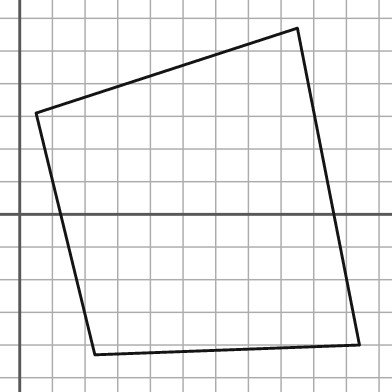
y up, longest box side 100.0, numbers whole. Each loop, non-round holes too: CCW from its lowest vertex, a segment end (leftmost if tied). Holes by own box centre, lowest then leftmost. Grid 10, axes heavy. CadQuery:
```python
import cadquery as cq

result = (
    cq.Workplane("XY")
    .moveTo(23.0, -43.0)
    .lineTo(104.0, -40.0)
    .lineTo(85.0, 57.0)
    .lineTo(5.0, 31.0)
    .close()
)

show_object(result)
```